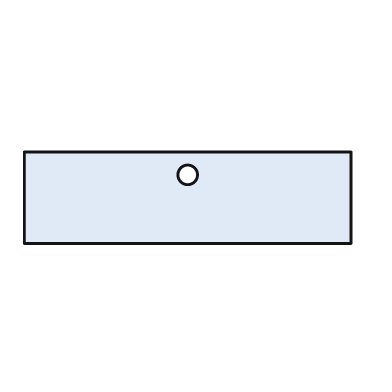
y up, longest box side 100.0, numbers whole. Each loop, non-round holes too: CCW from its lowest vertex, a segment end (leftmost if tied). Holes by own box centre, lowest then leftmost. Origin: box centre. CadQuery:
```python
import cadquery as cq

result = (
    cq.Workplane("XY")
    .moveTo(-50.0, -14.0)
    .lineTo(50.0, -14.0)
    .lineTo(50.0, 14.0)
    .lineTo(-50.0, 14.0)
    .close()
    .moveTo(0.0, 7.0)
    .circle(3.0)
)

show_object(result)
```